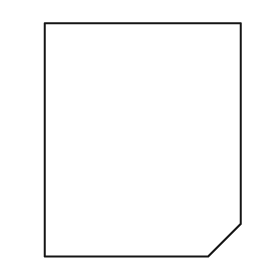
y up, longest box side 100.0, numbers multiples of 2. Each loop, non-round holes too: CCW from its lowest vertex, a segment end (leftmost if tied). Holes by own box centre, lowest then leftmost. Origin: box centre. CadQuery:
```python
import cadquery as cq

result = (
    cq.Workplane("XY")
    .moveTo(-42.0, -50.0)
    .lineTo(28.0, -50.0)
    .lineTo(42.0, -36.0)
    .lineTo(42.0, 50.0)
    .lineTo(-42.0, 50.0)
    .close()
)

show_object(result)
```